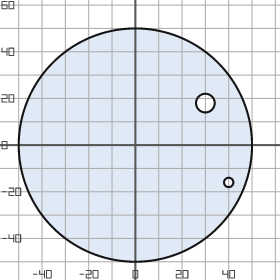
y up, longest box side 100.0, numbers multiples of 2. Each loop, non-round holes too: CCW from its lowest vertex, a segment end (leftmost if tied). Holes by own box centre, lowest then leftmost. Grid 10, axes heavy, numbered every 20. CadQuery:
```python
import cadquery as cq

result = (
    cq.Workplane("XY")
    .moveTo(0.0, 0.0)
    .circle(50.0)
    .moveTo(40.0, -16.0)
    .circle(2.0)
    .moveTo(30.0, 18.0)
    .circle(4.0)
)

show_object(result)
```